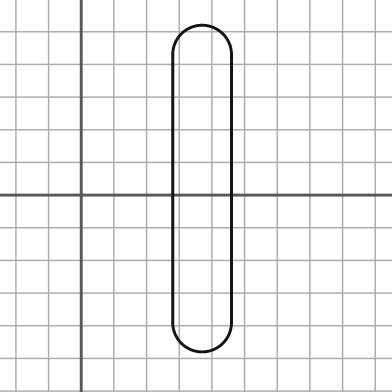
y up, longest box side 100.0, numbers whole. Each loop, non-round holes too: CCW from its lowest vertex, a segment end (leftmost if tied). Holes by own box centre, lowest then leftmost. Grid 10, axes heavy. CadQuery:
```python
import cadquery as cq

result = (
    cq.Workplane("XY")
    .moveTo(28.0, -39.0)
    .threePointArc((37.0, -48.0), (46.0, -39.0))
    .lineTo(46.0, 43.0)
    .threePointArc((37.0, 52.0), (28.0, 43.0))
    .close()
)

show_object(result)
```